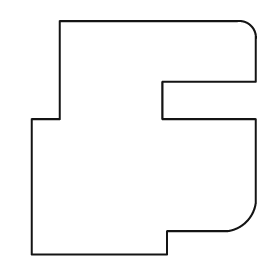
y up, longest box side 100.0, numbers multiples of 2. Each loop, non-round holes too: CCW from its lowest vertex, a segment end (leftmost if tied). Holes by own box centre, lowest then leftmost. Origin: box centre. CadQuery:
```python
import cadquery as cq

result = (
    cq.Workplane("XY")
    .moveTo(-48.0, -50.0)
    .lineTo(10.0, -50.0)
    .lineTo(10.0, -40.0)
    .lineTo(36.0, -40.0)
    .threePointArc((44.0, -36.0), (48.0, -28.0))
    .lineTo(48.0, 8.0)
    .lineTo(8.0, 8.0)
    .lineTo(8.0, 24.0)
    .lineTo(48.0, 24.0)
    .lineTo(48.0, 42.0)
    .threePointArc((46.0, 48.0), (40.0, 50.0))
    .lineTo(-36.0, 50.0)
    .lineTo(-36.0, 8.0)
    .lineTo(-48.0, 8.0)
    .close()
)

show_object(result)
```